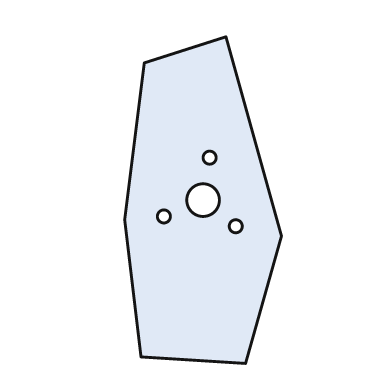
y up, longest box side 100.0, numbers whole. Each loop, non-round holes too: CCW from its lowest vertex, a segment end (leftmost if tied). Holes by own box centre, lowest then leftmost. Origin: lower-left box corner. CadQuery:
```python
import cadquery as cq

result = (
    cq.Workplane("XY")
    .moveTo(37.0, 0.0)
    .lineTo(48.0, 39.0)
    .lineTo(31.0, 100.0)
    .lineTo(6.0, 92.0)
    .lineTo(0.0, 44.0)
    .lineTo(5.0, 2.0)
    .close()
    .moveTo(34.0, 42.0)
    .circle(2.0)
    .moveTo(12.0, 45.0)
    .circle(2.0)
    .moveTo(24.0, 50.0)
    .circle(5.0)
    .moveTo(26.0, 63.0)
    .circle(2.0)
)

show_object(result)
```